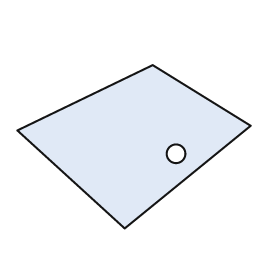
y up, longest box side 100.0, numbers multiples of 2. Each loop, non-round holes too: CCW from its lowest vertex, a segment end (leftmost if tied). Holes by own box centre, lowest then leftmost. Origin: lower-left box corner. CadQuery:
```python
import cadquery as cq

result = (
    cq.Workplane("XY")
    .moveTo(46.0, 0.0)
    .lineTo(100.0, 44.0)
    .lineTo(58.0, 70.0)
    .lineTo(0.0, 42.0)
    .close()
    .moveTo(68.0, 32.0)
    .circle(4.0)
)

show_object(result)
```